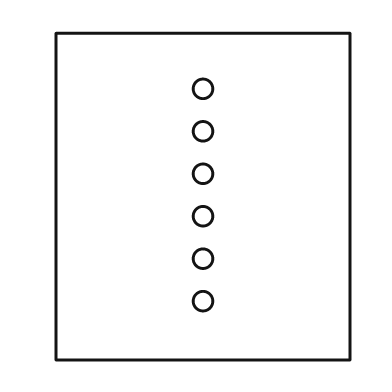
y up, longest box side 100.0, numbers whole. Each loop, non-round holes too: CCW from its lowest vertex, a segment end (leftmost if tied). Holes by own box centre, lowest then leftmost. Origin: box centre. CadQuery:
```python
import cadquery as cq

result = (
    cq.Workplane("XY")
    .moveTo(-45.0, -50.0)
    .lineTo(45.0, -50.0)
    .lineTo(45.0, 50.0)
    .lineTo(-45.0, 50.0)
    .close()
    .moveTo(0.0, -32.0)
    .circle(3.0)
    .moveTo(0.0, -19.0)
    .circle(3.0)
    .moveTo(0.0, -6.0)
    .circle(3.0)
    .moveTo(0.0, 7.0)
    .circle(3.0)
    .moveTo(0.0, 20.0)
    .circle(3.0)
    .moveTo(0.0, 33.0)
    .circle(3.0)
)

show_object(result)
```